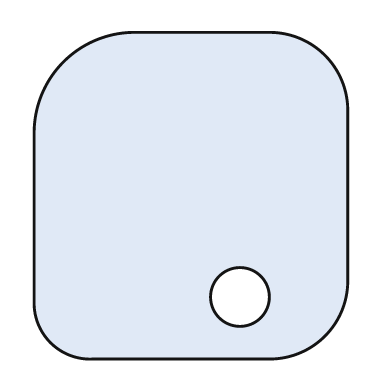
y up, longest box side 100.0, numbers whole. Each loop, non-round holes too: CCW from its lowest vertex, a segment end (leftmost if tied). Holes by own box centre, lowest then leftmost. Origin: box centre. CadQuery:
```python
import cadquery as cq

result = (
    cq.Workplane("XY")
    .moveTo(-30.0, -50.0)
    .lineTo(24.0, -50.0)
    .threePointArc((41.0, -43.0), (48.0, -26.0))
    .lineTo(48.0, 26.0)
    .threePointArc((41.0, 43.0), (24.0, 50.0))
    .lineTo(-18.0, 50.0)
    .threePointArc((-39.0, 41.0), (-48.0, 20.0))
    .lineTo(-48.0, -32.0)
    .threePointArc((-43.0, -45.0), (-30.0, -50.0))
    .close()
    .moveTo(15.0, -31.0)
    .circle(9.0)
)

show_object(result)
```